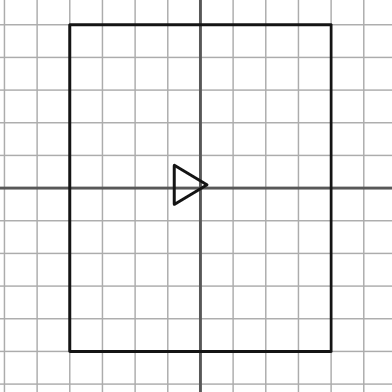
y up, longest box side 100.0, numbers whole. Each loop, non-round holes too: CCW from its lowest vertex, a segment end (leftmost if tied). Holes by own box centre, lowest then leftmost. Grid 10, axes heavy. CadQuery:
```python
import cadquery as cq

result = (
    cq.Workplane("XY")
    .moveTo(-40.0, -50.0)
    .lineTo(40.0, -50.0)
    .lineTo(40.0, 50.0)
    .lineTo(-40.0, 50.0)
    .close()
    .moveTo(-8.0, -5.0)
    .lineTo(2.0, 1.0)
    .lineTo(-8.0, 7.0)
    .close()
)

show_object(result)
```